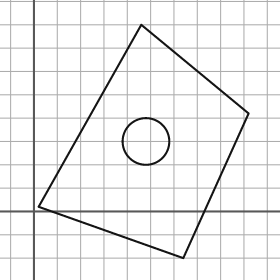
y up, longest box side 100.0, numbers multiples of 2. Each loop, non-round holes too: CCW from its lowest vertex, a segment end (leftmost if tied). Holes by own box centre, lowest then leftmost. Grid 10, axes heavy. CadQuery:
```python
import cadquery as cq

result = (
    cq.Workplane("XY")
    .moveTo(64.0, -20.0)
    .lineTo(92.0, 42.0)
    .lineTo(46.0, 80.0)
    .lineTo(2.0, 2.0)
    .close()
    .moveTo(48.0, 30.0)
    .circle(10.0)
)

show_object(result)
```